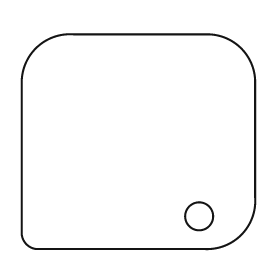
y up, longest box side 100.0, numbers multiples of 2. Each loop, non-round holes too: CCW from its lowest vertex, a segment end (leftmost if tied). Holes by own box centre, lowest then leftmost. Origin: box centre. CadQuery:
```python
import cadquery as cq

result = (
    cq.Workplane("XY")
    .moveTo(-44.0, -46.0)
    .lineTo(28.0, -46.0)
    .threePointArc((44.0, -40.0), (50.0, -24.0))
    .lineTo(50.0, 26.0)
    .threePointArc((44.0, 40.0), (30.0, 46.0))
    .lineTo(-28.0, 46.0)
    .threePointArc((-44.0, 40.0), (-50.0, 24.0))
    .lineTo(-50.0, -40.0)
    .threePointArc((-48.0, -44.0), (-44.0, -46.0))
    .close()
    .moveTo(26.0, -32.0)
    .circle(6.0)
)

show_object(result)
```